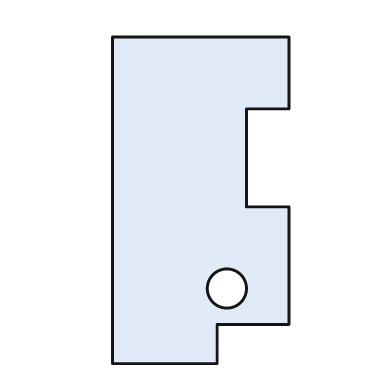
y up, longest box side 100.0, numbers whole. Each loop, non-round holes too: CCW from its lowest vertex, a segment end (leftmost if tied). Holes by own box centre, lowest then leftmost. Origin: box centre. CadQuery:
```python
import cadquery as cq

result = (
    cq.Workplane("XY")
    .moveTo(-27.0, -50.0)
    .lineTo(5.0, -50.0)
    .lineTo(5.0, -38.0)
    .lineTo(27.0, -38.0)
    .lineTo(27.0, -2.0)
    .lineTo(14.0, -2.0)
    .lineTo(14.0, 28.0)
    .lineTo(27.0, 28.0)
    .lineTo(27.0, 50.0)
    .lineTo(-27.0, 50.0)
    .close()
    .moveTo(8.0, -27.0)
    .circle(6.0)
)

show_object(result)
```